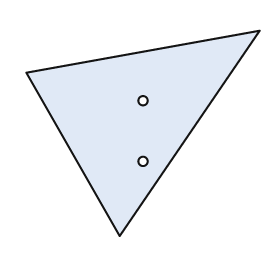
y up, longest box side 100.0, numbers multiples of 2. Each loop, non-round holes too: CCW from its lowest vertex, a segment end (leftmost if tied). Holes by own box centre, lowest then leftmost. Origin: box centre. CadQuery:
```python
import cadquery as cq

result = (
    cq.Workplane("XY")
    .moveTo(-10.0, -44.0)
    .lineTo(50.0, 44.0)
    .lineTo(-50.0, 26.0)
    .close()
    .moveTo(0.0, -12.0)
    .circle(2.0)
    .moveTo(0.0, 14.0)
    .circle(2.0)
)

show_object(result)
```